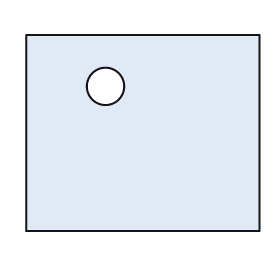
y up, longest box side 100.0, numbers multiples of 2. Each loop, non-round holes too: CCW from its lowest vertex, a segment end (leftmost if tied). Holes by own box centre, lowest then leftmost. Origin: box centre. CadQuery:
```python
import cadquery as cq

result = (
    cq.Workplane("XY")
    .moveTo(-50.0, -42.0)
    .lineTo(50.0, -42.0)
    .lineTo(50.0, 42.0)
    .lineTo(-50.0, 42.0)
    .close()
    .moveTo(-16.0, 20.0)
    .circle(8.0)
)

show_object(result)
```